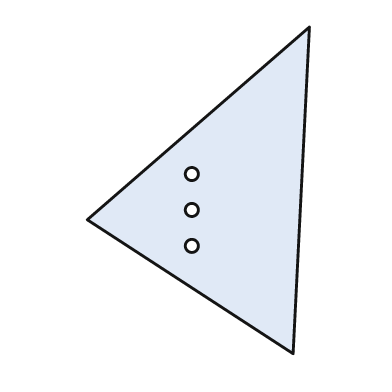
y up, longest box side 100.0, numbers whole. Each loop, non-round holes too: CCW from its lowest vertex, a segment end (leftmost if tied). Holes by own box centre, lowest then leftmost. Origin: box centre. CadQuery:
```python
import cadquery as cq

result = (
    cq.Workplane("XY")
    .moveTo(29.0, -50.0)
    .lineTo(34.0, 50.0)
    .lineTo(-34.0, -9.0)
    .close()
    .moveTo(-2.0, -17.0)
    .circle(2.0)
    .moveTo(-2.0, -6.0)
    .circle(2.0)
    .moveTo(-2.0, 5.0)
    .circle(2.0)
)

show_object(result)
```